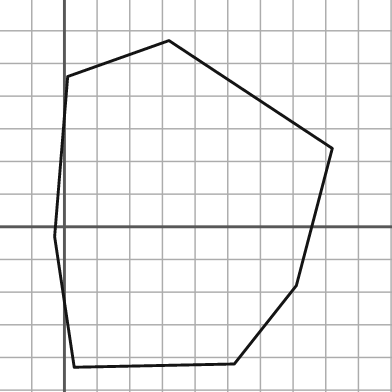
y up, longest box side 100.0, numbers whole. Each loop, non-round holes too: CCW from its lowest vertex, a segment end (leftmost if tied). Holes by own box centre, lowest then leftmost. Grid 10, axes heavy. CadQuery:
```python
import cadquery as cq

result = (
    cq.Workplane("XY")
    .moveTo(3.0, -43.0)
    .lineTo(52.0, -42.0)
    .lineTo(71.0, -18.0)
    .lineTo(82.0, 24.0)
    .lineTo(32.0, 57.0)
    .lineTo(1.0, 46.0)
    .lineTo(-3.0, -3.0)
    .close()
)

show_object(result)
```